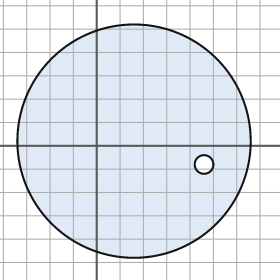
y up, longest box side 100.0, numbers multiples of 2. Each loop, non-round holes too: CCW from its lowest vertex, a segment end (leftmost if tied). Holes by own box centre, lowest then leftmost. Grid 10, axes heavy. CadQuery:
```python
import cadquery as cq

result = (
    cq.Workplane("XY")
    .moveTo(16.0, 2.0)
    .circle(50.0)
    .moveTo(46.0, -8.0)
    .circle(4.0)
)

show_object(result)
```